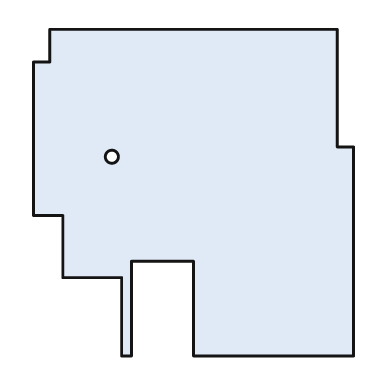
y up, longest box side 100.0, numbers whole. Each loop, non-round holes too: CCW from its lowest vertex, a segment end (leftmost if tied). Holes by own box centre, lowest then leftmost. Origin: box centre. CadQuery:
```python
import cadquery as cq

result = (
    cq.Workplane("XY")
    .moveTo(-22.0, -50.0)
    .lineTo(-19.0, -50.0)
    .lineTo(-19.0, -21.0)
    .lineTo(0.0, -21.0)
    .lineTo(0.0, -50.0)
    .lineTo(49.0, -50.0)
    .lineTo(49.0, 14.0)
    .lineTo(44.0, 14.0)
    .lineTo(44.0, 50.0)
    .lineTo(-44.0, 50.0)
    .lineTo(-44.0, 40.0)
    .lineTo(-49.0, 40.0)
    .lineTo(-49.0, -7.0)
    .lineTo(-40.0, -7.0)
    .lineTo(-40.0, -26.0)
    .lineTo(-22.0, -26.0)
    .close()
    .moveTo(-25.0, 11.0)
    .circle(2.0)
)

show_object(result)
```